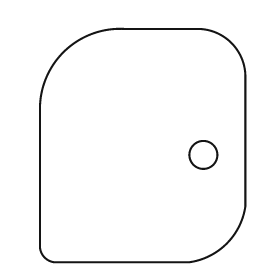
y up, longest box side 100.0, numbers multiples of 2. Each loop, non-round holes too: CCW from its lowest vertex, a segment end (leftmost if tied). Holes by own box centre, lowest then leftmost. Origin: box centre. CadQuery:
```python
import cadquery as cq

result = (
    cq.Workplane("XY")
    .moveTo(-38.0, -50.0)
    .lineTo(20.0, -50.0)
    .threePointArc((36.0, -42.0), (44.0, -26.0))
    .lineTo(44.0, 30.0)
    .threePointArc((38.0, 44.0), (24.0, 50.0))
    .lineTo(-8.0, 50.0)
    .threePointArc((-34.0, 40.0), (-44.0, 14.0))
    .lineTo(-44.0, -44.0)
    .threePointArc((-42.0, -48.0), (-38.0, -50.0))
    .close()
    .moveTo(26.0, -4.0)
    .circle(6.0)
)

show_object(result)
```